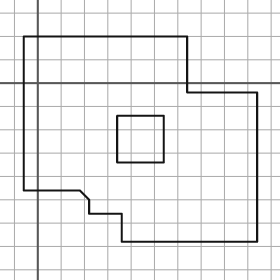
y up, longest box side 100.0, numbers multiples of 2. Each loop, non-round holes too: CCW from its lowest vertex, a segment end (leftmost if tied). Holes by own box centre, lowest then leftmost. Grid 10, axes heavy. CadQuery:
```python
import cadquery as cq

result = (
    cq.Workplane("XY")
    .moveTo(36.0, -68.0)
    .lineTo(94.0, -68.0)
    .lineTo(94.0, -4.0)
    .lineTo(64.0, -4.0)
    .lineTo(64.0, 20.0)
    .lineTo(-6.0, 20.0)
    .lineTo(-6.0, -46.0)
    .lineTo(18.0, -46.0)
    .lineTo(22.0, -50.0)
    .lineTo(22.0, -56.0)
    .lineTo(36.0, -56.0)
    .close()
    .moveTo(34.0, -34.0)
    .lineTo(54.0, -34.0)
    .lineTo(54.0, -14.0)
    .lineTo(34.0, -14.0)
    .close()
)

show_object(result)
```